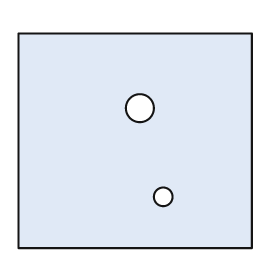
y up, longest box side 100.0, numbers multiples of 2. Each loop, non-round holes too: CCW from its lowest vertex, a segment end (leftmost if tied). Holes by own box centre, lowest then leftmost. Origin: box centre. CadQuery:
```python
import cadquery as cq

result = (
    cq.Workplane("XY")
    .moveTo(-50.0, -46.0)
    .lineTo(50.0, -46.0)
    .lineTo(50.0, 46.0)
    .lineTo(-50.0, 46.0)
    .close()
    .moveTo(12.0, -24.0)
    .circle(4.0)
    .moveTo(2.0, 14.0)
    .circle(6.0)
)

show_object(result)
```